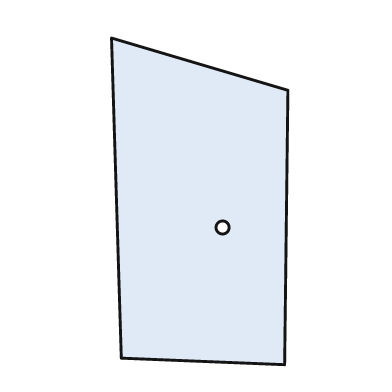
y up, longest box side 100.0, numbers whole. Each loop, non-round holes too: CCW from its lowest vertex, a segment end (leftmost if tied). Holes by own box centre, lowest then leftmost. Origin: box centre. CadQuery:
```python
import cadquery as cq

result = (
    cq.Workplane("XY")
    .moveTo(26.0, -50.0)
    .lineTo(27.0, 34.0)
    .lineTo(-27.0, 50.0)
    .lineTo(-24.0, -48.0)
    .close()
    .moveTo(7.0, -8.0)
    .circle(2.0)
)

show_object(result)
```